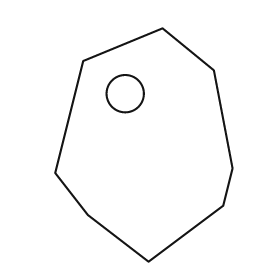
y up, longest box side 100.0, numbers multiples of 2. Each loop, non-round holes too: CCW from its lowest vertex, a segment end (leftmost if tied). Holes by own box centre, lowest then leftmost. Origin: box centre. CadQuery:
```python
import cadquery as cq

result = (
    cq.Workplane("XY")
    .moveTo(2.0, -50.0)
    .lineTo(34.0, -26.0)
    .lineTo(38.0, -10.0)
    .lineTo(30.0, 32.0)
    .lineTo(8.0, 50.0)
    .lineTo(-26.0, 36.0)
    .lineTo(-38.0, -12.0)
    .lineTo(-24.0, -30.0)
    .close()
    .moveTo(-8.0, 22.0)
    .circle(8.0)
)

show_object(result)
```